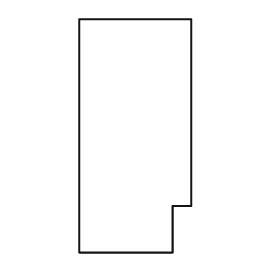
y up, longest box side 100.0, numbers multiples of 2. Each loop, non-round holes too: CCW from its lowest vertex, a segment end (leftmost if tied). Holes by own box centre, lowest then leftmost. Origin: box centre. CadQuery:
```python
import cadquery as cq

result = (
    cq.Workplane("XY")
    .moveTo(-24.0, -50.0)
    .lineTo(16.0, -50.0)
    .lineTo(16.0, -30.0)
    .lineTo(24.0, -30.0)
    .lineTo(24.0, 50.0)
    .lineTo(-24.0, 50.0)
    .close()
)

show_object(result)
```